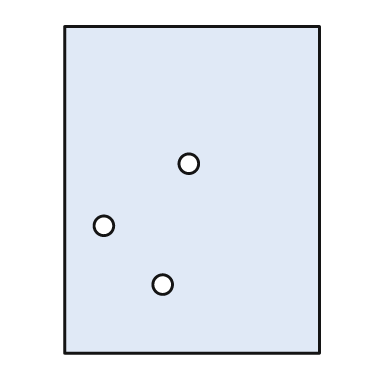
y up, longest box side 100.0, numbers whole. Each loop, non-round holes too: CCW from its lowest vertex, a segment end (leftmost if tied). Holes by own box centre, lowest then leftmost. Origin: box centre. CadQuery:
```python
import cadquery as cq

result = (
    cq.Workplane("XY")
    .moveTo(-39.0, -50.0)
    .lineTo(39.0, -50.0)
    .lineTo(39.0, 50.0)
    .lineTo(-39.0, 50.0)
    .close()
    .moveTo(-9.0, -29.0)
    .circle(3.0)
    .moveTo(-27.0, -11.0)
    .circle(3.0)
    .moveTo(-1.0, 8.0)
    .circle(3.0)
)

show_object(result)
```